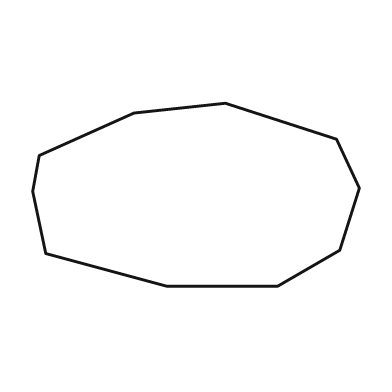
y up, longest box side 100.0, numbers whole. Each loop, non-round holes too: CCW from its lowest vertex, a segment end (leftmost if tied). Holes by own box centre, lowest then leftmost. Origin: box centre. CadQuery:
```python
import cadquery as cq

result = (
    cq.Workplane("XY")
    .moveTo(-9.0, -28.0)
    .lineTo(25.0, -28.0)
    .lineTo(44.0, -17.0)
    .lineTo(50.0, 2.0)
    .lineTo(43.0, 17.0)
    .lineTo(9.0, 28.0)
    .lineTo(-19.0, 25.0)
    .lineTo(-48.0, 12.0)
    .lineTo(-50.0, 1.0)
    .lineTo(-46.0, -18.0)
    .close()
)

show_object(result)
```